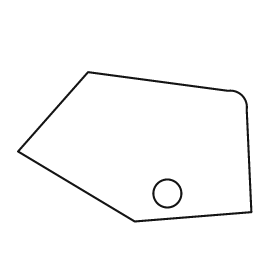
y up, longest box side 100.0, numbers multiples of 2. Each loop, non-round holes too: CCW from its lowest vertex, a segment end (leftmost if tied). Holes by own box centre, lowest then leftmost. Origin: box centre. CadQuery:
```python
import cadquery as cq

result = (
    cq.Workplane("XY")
    .moveTo(0.0, -32.0)
    .lineTo(50.0, -28.0)
    .lineTo(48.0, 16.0)
    .threePointArc((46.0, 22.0), (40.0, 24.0))
    .lineTo(-20.0, 32.0)
    .lineTo(-50.0, -2.0)
    .close()
    .moveTo(14.0, -20.0)
    .circle(6.0)
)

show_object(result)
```